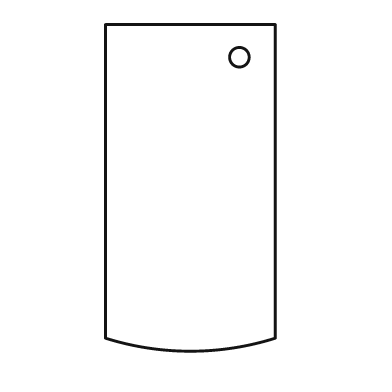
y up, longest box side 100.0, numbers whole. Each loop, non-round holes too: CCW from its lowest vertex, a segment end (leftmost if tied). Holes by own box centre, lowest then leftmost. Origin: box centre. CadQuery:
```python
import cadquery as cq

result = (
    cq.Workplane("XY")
    .moveTo(-26.0, -46.0)
    .threePointArc((0.0, -50.0), (26.0, -46.0))
    .lineTo(26.0, 50.0)
    .lineTo(-26.0, 50.0)
    .close()
    .moveTo(15.0, 40.0)
    .circle(3.0)
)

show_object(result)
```